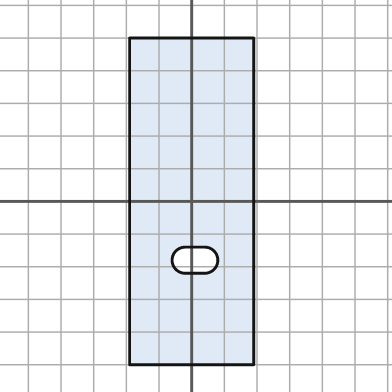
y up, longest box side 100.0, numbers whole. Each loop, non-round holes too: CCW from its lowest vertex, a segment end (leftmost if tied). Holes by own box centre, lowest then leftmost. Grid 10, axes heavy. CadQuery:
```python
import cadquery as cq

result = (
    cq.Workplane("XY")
    .moveTo(-19.0, -50.0)
    .lineTo(19.0, -50.0)
    .lineTo(19.0, 50.0)
    .lineTo(-19.0, 50.0)
    .close()
    .moveTo(-2.0, -22.0)
    .lineTo(4.0, -22.0)
    .threePointArc((8.0, -18.0), (4.0, -14.0))
    .lineTo(-2.0, -14.0)
    .threePointArc((-6.0, -18.0), (-2.0, -22.0))
    .close()
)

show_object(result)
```